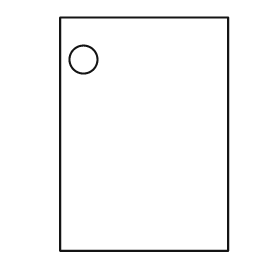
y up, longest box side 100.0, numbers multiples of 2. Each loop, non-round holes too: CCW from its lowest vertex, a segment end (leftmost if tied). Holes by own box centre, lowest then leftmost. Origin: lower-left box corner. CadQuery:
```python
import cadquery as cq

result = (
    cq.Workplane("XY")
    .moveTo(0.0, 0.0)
    .lineTo(72.0, 0.0)
    .lineTo(72.0, 100.0)
    .lineTo(0.0, 100.0)
    .close()
    .moveTo(10.0, 82.0)
    .circle(6.0)
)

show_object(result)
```